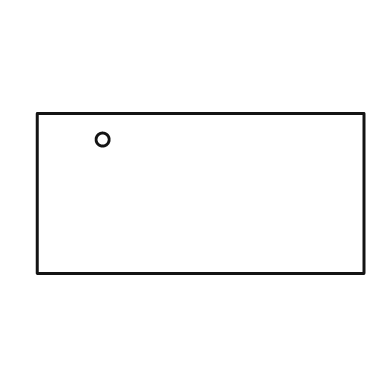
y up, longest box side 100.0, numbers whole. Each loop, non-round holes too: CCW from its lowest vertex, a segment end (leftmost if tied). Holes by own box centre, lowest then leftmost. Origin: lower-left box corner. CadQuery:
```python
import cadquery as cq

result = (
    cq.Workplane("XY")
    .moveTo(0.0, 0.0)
    .lineTo(100.0, 0.0)
    .lineTo(100.0, 49.0)
    .lineTo(0.0, 49.0)
    .close()
    .moveTo(20.0, 41.0)
    .circle(2.0)
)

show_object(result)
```